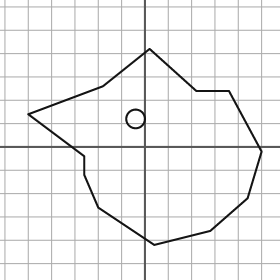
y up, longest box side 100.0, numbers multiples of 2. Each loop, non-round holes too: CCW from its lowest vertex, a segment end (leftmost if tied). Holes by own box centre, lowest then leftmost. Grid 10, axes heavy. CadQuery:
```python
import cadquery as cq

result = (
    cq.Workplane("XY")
    .moveTo(4.0, -42.0)
    .lineTo(28.0, -36.0)
    .lineTo(44.0, -22.0)
    .lineTo(50.0, -2.0)
    .lineTo(36.0, 24.0)
    .lineTo(22.0, 24.0)
    .lineTo(2.0, 42.0)
    .lineTo(-18.0, 26.0)
    .lineTo(-50.0, 14.0)
    .lineTo(-26.0, -4.0)
    .lineTo(-26.0, -12.0)
    .lineTo(-20.0, -26.0)
    .close()
    .moveTo(-4.0, 12.0)
    .circle(4.0)
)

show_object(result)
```